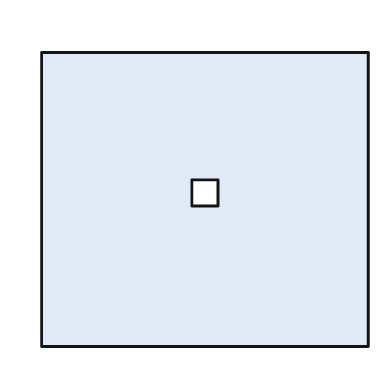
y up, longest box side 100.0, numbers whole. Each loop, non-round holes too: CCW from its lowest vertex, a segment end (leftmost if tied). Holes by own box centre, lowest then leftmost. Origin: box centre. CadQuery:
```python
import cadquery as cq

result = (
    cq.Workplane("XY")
    .moveTo(-50.0, -45.0)
    .lineTo(50.0, -45.0)
    .lineTo(50.0, 45.0)
    .lineTo(-50.0, 45.0)
    .close()
    .moveTo(-4.0, -2.0)
    .lineTo(4.0, -2.0)
    .lineTo(4.0, 6.0)
    .lineTo(-4.0, 6.0)
    .close()
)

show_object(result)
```